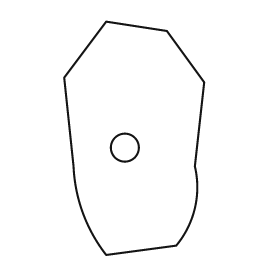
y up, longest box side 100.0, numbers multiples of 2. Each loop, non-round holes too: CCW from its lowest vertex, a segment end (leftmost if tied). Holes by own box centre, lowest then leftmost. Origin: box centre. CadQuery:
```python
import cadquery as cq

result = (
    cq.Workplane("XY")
    .moveTo(-12.0, -50.0)
    .lineTo(18.0, -46.0)
    .threePointArc((26.0, -30.0), (26.0, -12.0))
    .lineTo(30.0, 24.0)
    .lineTo(14.0, 46.0)
    .lineTo(-12.0, 50.0)
    .lineTo(-30.0, 26.0)
    .lineTo(-26.0, -12.0)
    .threePointArc((-22.0, -32.0), (-12.0, -50.0))
    .close()
    .moveTo(-4.0, -4.0)
    .circle(6.0)
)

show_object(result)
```